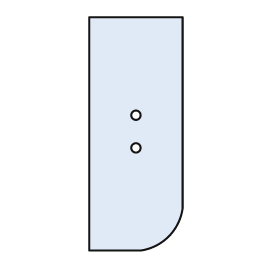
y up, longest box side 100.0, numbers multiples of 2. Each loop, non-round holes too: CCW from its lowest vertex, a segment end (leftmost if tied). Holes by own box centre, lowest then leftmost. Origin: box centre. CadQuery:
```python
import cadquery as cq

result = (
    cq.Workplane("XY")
    .moveTo(-20.0, -50.0)
    .lineTo(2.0, -50.0)
    .threePointArc((14.0, -44.0), (20.0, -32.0))
    .lineTo(20.0, 50.0)
    .lineTo(-20.0, 50.0)
    .close()
    .moveTo(0.0, -6.0)
    .circle(2.0)
    .moveTo(0.0, 8.0)
    .circle(2.0)
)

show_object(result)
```